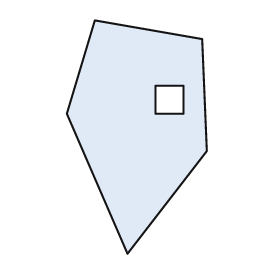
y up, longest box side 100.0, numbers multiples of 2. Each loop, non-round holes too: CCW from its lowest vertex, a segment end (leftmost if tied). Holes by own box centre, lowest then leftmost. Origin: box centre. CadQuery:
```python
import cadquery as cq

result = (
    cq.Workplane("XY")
    .moveTo(-4.0, -50.0)
    .lineTo(30.0, -6.0)
    .lineTo(28.0, 42.0)
    .lineTo(-18.0, 50.0)
    .lineTo(-30.0, 10.0)
    .close()
    .moveTo(8.0, 10.0)
    .lineTo(20.0, 10.0)
    .lineTo(20.0, 22.0)
    .lineTo(8.0, 22.0)
    .close()
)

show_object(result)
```